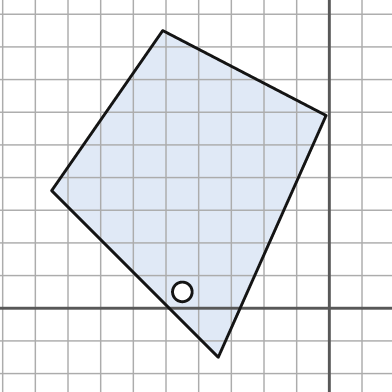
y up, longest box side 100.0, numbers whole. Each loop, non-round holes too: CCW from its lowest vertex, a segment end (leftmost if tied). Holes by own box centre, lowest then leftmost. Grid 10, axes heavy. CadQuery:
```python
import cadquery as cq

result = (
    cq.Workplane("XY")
    .moveTo(-34.0, -15.0)
    .lineTo(-1.0, 59.0)
    .lineTo(-51.0, 85.0)
    .lineTo(-85.0, 36.0)
    .close()
    .moveTo(-45.0, 5.0)
    .circle(3.0)
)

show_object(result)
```